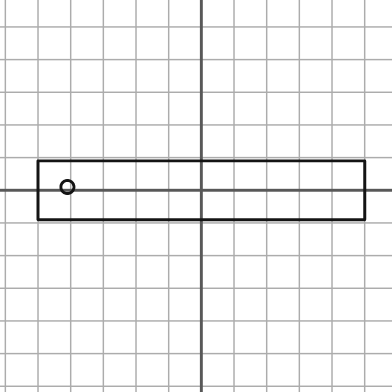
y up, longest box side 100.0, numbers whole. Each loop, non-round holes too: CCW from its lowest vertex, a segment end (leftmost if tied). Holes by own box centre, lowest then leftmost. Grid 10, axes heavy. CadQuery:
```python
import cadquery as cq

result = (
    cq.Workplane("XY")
    .moveTo(-50.0, -9.0)
    .lineTo(50.0, -9.0)
    .lineTo(50.0, 9.0)
    .lineTo(-50.0, 9.0)
    .close()
    .moveTo(-41.0, 1.0)
    .circle(2.0)
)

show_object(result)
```